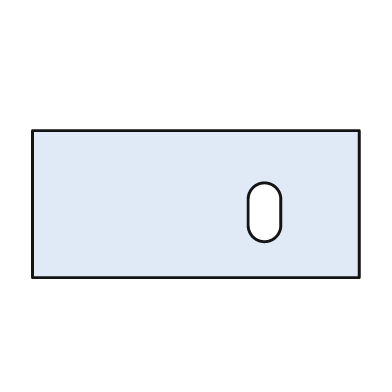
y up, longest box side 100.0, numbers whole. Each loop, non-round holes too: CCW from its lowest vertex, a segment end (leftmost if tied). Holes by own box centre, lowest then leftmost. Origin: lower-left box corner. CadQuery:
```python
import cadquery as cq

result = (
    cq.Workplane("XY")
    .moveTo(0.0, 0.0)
    .lineTo(100.0, 0.0)
    .lineTo(100.0, 45.0)
    .lineTo(0.0, 45.0)
    .close()
    .moveTo(66.0, 16.0)
    .threePointArc((71.0, 11.0), (76.0, 16.0))
    .lineTo(76.0, 24.0)
    .threePointArc((71.0, 29.0), (66.0, 24.0))
    .close()
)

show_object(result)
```